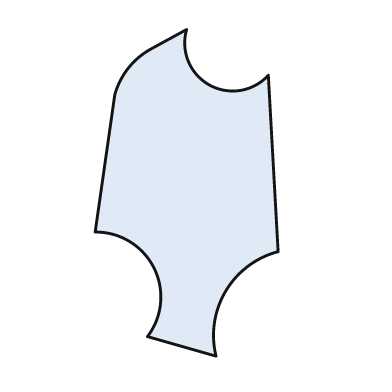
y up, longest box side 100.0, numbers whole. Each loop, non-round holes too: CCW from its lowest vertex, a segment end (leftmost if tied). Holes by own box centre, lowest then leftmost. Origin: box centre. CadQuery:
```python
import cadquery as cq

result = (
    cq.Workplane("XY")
    .moveTo(9.0, -50.0)
    .threePointArc((12.0, -30.0), (28.0, -18.0))
    .lineTo(25.0, 36.0)
    .threePointArc((7.0, 33.0), (0.0, 50.0))
    .lineTo(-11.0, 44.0)
    .threePointArc((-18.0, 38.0), (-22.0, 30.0))
    .lineTo(-28.0, -12.0)
    .threePointArc((-10.0, -23.0), (-12.0, -44.0))
    .close()
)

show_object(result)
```